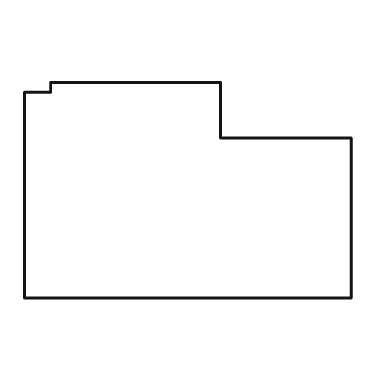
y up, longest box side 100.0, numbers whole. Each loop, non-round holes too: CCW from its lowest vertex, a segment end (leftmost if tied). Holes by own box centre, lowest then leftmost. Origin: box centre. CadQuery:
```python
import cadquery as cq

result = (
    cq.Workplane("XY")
    .moveTo(-50.0, -33.0)
    .lineTo(50.0, -33.0)
    .lineTo(50.0, 16.0)
    .lineTo(10.0, 16.0)
    .lineTo(10.0, 33.0)
    .lineTo(-42.0, 33.0)
    .lineTo(-42.0, 30.0)
    .lineTo(-50.0, 30.0)
    .close()
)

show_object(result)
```